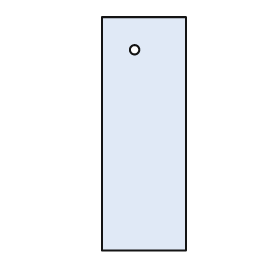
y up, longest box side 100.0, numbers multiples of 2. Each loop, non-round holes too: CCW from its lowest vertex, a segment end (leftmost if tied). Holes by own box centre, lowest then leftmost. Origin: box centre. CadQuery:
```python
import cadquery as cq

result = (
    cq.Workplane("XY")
    .moveTo(-18.0, -50.0)
    .lineTo(18.0, -50.0)
    .lineTo(18.0, 50.0)
    .lineTo(-18.0, 50.0)
    .close()
    .moveTo(-4.0, 36.0)
    .circle(2.0)
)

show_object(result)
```